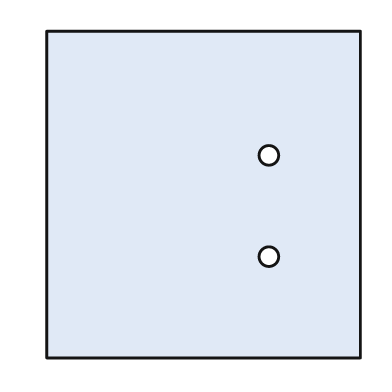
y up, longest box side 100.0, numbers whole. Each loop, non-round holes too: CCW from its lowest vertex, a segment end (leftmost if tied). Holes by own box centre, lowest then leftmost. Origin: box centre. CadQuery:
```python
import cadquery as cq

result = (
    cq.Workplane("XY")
    .moveTo(-48.0, -50.0)
    .lineTo(48.0, -50.0)
    .lineTo(48.0, 50.0)
    .lineTo(-48.0, 50.0)
    .close()
    .moveTo(20.0, -19.0)
    .circle(3.0)
    .moveTo(20.0, 12.0)
    .circle(3.0)
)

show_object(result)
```